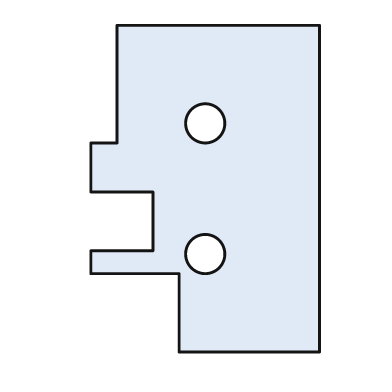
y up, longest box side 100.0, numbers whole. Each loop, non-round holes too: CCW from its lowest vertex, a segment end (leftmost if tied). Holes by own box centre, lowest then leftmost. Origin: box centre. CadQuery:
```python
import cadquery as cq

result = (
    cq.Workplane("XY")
    .moveTo(-8.0, -50.0)
    .lineTo(35.0, -50.0)
    .lineTo(35.0, 50.0)
    .lineTo(-27.0, 50.0)
    .lineTo(-27.0, 14.0)
    .lineTo(-35.0, 14.0)
    .lineTo(-35.0, -1.0)
    .lineTo(-16.0, -1.0)
    .lineTo(-16.0, -19.0)
    .lineTo(-35.0, -19.0)
    .lineTo(-35.0, -26.0)
    .lineTo(-8.0, -26.0)
    .close()
    .moveTo(0.0, -20.0)
    .circle(6.0)
    .moveTo(0.0, 20.0)
    .circle(6.0)
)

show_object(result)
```